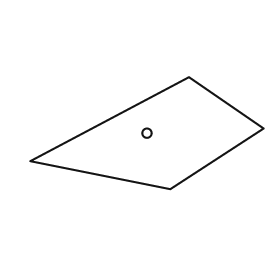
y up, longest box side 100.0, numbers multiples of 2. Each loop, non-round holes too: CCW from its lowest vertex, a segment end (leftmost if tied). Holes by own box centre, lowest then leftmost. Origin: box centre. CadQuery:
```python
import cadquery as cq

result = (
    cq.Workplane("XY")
    .moveTo(10.0, -24.0)
    .lineTo(50.0, 2.0)
    .lineTo(18.0, 24.0)
    .lineTo(-50.0, -12.0)
    .close()
    .moveTo(0.0, 0.0)
    .circle(2.0)
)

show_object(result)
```